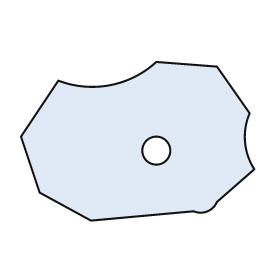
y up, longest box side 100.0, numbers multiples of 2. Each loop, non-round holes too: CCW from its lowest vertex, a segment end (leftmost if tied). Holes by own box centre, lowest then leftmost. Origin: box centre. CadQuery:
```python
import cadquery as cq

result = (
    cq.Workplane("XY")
    .moveTo(-20.0, -34.0)
    .lineTo(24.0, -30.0)
    .threePointArc((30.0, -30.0), (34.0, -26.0))
    .lineTo(50.0, -12.0)
    .threePointArc((46.0, 0.0), (48.0, 12.0))
    .lineTo(34.0, 32.0)
    .lineTo(8.0, 34.0)
    .threePointArc((-12.0, 24.0), (-34.0, 26.0))
    .lineTo(-50.0, 2.0)
    .lineTo(-42.0, -22.0)
    .close()
    .moveTo(8.0, -4.0)
    .circle(6.0)
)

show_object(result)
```